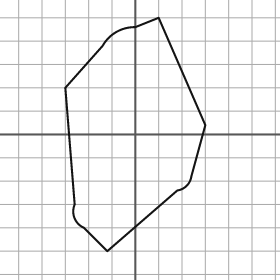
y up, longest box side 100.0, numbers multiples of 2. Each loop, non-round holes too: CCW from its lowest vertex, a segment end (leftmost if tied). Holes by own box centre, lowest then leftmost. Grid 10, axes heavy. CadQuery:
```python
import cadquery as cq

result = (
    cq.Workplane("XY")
    .moveTo(-12.0, -50.0)
    .lineTo(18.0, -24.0)
    .threePointArc((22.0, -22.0), (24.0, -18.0))
    .lineTo(30.0, 4.0)
    .lineTo(10.0, 50.0)
    .lineTo(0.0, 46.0)
    .threePointArc((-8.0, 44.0), (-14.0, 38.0))
    .lineTo(-30.0, 20.0)
    .lineTo(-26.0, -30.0)
    .threePointArc((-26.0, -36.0), (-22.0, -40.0))
    .close()
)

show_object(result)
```